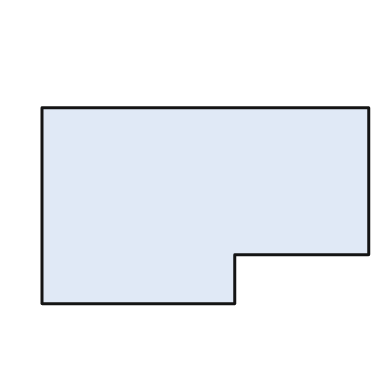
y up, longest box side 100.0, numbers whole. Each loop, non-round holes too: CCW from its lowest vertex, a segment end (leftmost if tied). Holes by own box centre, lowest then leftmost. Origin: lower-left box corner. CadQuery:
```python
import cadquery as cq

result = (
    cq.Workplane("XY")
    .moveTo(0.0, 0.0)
    .lineTo(59.0, 0.0)
    .lineTo(59.0, 15.0)
    .lineTo(100.0, 15.0)
    .lineTo(100.0, 60.0)
    .lineTo(0.0, 60.0)
    .close()
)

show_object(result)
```